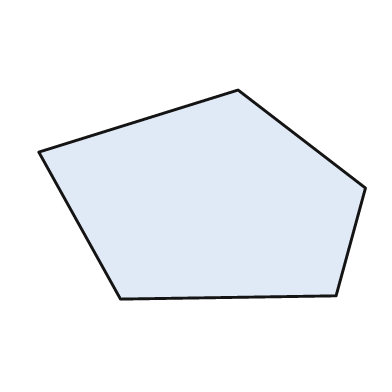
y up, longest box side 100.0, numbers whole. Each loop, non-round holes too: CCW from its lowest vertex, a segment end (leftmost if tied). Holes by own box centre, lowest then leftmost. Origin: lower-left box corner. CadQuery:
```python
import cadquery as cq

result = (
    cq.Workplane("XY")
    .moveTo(25.0, 0.0)
    .lineTo(91.0, 1.0)
    .lineTo(100.0, 34.0)
    .lineTo(61.0, 64.0)
    .lineTo(0.0, 45.0)
    .close()
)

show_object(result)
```